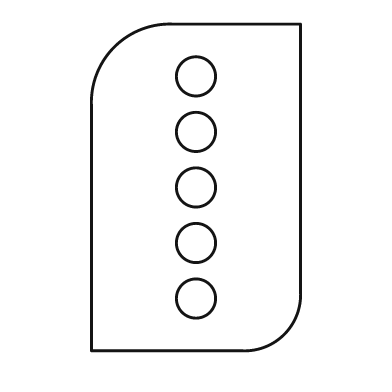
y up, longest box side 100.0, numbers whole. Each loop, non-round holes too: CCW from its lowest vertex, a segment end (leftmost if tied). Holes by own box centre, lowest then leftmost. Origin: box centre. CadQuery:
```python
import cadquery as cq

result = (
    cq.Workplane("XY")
    .moveTo(-32.0, -50.0)
    .lineTo(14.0, -50.0)
    .threePointArc((27.0, -45.0), (32.0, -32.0))
    .lineTo(32.0, 50.0)
    .lineTo(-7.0, 50.0)
    .threePointArc((-25.0, 43.0), (-32.0, 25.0))
    .close()
    .moveTo(0.0, -34.0)
    .circle(6.0)
    .moveTo(0.0, -17.0)
    .circle(6.0)
    .moveTo(0.0, 0.0)
    .circle(6.0)
    .moveTo(0.0, 17.0)
    .circle(6.0)
    .moveTo(0.0, 34.0)
    .circle(6.0)
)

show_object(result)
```